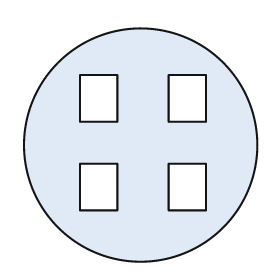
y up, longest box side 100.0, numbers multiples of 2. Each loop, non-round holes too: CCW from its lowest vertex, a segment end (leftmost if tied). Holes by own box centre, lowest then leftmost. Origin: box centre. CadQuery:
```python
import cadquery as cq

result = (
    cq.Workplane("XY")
    .moveTo(0.0, 0.0)
    .circle(50.0)
    .moveTo(-26.0, -28.0)
    .lineTo(-10.0, -28.0)
    .lineTo(-10.0, -8.0)
    .lineTo(-26.0, -8.0)
    .close()
    .moveTo(12.0, -28.0)
    .lineTo(28.0, -28.0)
    .lineTo(28.0, -8.0)
    .lineTo(12.0, -8.0)
    .close()
    .moveTo(-26.0, 10.0)
    .lineTo(-10.0, 10.0)
    .lineTo(-10.0, 30.0)
    .lineTo(-26.0, 30.0)
    .close()
    .moveTo(12.0, 10.0)
    .lineTo(28.0, 10.0)
    .lineTo(28.0, 30.0)
    .lineTo(12.0, 30.0)
    .close()
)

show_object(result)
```